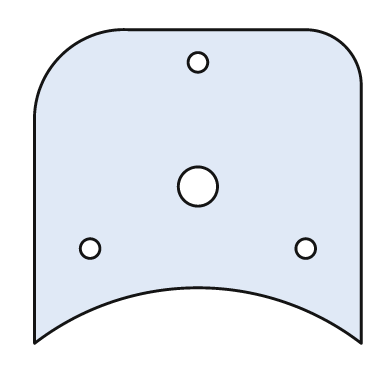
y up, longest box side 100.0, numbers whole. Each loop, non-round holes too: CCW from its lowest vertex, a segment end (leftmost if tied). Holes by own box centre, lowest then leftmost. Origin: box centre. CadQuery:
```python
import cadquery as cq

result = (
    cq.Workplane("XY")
    .moveTo(-50.0, -48.0)
    .threePointArc((0.0, -31.0), (50.0, -48.0))
    .lineTo(50.0, 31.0)
    .threePointArc((45.0, 43.0), (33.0, 48.0))
    .lineTo(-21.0, 48.0)
    .threePointArc((-42.0, 40.0), (-50.0, 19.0))
    .close()
    .moveTo(-33.0, -19.0)
    .circle(3.0)
    .moveTo(33.0, -19.0)
    .circle(3.0)
    .moveTo(0.0, 0.0)
    .circle(6.0)
    .moveTo(0.0, 38.0)
    .circle(3.0)
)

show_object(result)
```